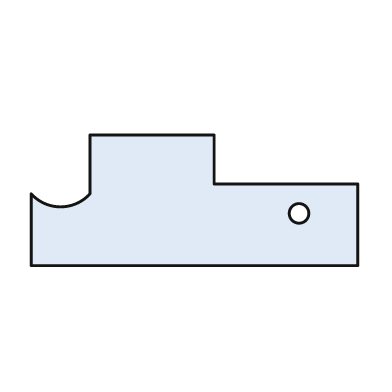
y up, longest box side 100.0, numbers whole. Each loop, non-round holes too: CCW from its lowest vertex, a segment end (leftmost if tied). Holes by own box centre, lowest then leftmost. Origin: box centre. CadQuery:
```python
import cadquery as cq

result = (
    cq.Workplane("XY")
    .moveTo(-50.0, -20.0)
    .lineTo(50.0, -20.0)
    .lineTo(50.0, 5.0)
    .lineTo(6.0, 5.0)
    .lineTo(6.0, 20.0)
    .lineTo(-32.0, 20.0)
    .lineTo(-32.0, 2.0)
    .threePointArc((-41.0, -2.0), (-50.0, 2.0))
    .close()
    .moveTo(32.0, -4.0)
    .circle(3.0)
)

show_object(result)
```